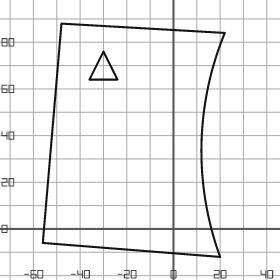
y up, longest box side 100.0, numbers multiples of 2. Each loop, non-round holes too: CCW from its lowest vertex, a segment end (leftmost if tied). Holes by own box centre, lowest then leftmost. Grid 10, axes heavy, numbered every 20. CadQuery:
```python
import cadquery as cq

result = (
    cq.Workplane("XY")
    .moveTo(20.0, -12.0)
    .threePointArc((12.0, 36.0), (22.0, 84.0))
    .lineTo(-48.0, 88.0)
    .lineTo(-56.0, -6.0)
    .close()
    .moveTo(-36.0, 64.0)
    .lineTo(-24.0, 64.0)
    .lineTo(-30.0, 76.0)
    .close()
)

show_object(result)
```